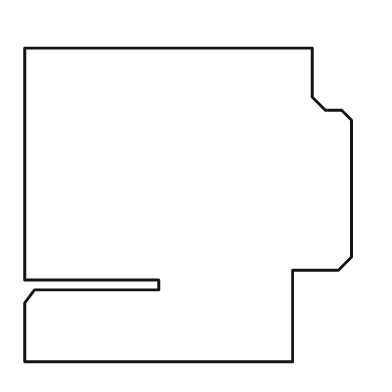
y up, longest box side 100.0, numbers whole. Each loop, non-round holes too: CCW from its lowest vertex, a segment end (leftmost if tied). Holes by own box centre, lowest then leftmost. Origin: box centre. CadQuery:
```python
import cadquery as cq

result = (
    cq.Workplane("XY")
    .moveTo(-50.0, -48.0)
    .lineTo(32.0, -48.0)
    .lineTo(32.0, -20.0)
    .lineTo(46.0, -20.0)
    .lineTo(50.0, -16.0)
    .lineTo(50.0, 26.0)
    .lineTo(47.0, 29.0)
    .lineTo(42.0, 29.0)
    .lineTo(38.0, 33.0)
    .lineTo(38.0, 48.0)
    .lineTo(-50.0, 48.0)
    .lineTo(-50.0, -23.0)
    .lineTo(-9.0, -23.0)
    .lineTo(-9.0, -26.0)
    .lineTo(-47.0, -26.0)
    .lineTo(-50.0, -30.0)
    .close()
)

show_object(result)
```